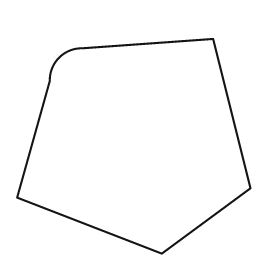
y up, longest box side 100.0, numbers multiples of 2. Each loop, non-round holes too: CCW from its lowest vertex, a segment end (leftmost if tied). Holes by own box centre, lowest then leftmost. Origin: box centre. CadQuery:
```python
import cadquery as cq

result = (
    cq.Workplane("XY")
    .moveTo(12.0, -46.0)
    .lineTo(50.0, -18.0)
    .lineTo(34.0, 46.0)
    .lineTo(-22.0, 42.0)
    .threePointArc((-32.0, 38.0), (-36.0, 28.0))
    .lineTo(-50.0, -22.0)
    .close()
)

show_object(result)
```